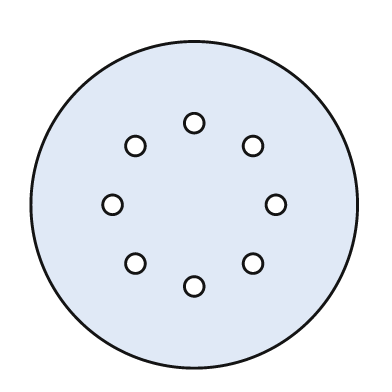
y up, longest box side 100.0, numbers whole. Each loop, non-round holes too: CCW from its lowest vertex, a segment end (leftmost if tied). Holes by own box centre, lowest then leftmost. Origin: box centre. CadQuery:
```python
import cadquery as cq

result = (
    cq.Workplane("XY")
    .moveTo(0.0, 0.0)
    .circle(50.0)
    .moveTo(0.0, -25.0)
    .circle(3.0)
    .moveTo(-18.0, -18.0)
    .circle(3.0)
    .moveTo(18.0, -18.0)
    .circle(3.0)
    .moveTo(-25.0, 0.0)
    .circle(3.0)
    .moveTo(25.0, 0.0)
    .circle(3.0)
    .moveTo(-18.0, 18.0)
    .circle(3.0)
    .moveTo(18.0, 18.0)
    .circle(3.0)
    .moveTo(0.0, 25.0)
    .circle(3.0)
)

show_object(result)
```